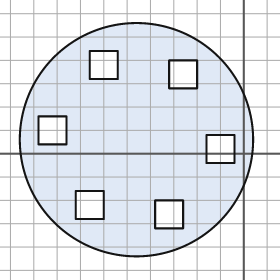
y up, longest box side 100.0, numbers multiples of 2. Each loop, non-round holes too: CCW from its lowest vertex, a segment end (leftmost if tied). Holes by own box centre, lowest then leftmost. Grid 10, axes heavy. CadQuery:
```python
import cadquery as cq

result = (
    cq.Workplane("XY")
    .moveTo(-46.0, 6.0)
    .circle(50.0)
    .moveTo(-38.0, -32.0)
    .lineTo(-26.0, -32.0)
    .lineTo(-26.0, -20.0)
    .lineTo(-38.0, -20.0)
    .close()
    .moveTo(-72.0, -28.0)
    .lineTo(-60.0, -28.0)
    .lineTo(-60.0, -16.0)
    .lineTo(-72.0, -16.0)
    .close()
    .moveTo(-16.0, -4.0)
    .lineTo(-4.0, -4.0)
    .lineTo(-4.0, 8.0)
    .lineTo(-16.0, 8.0)
    .close()
    .moveTo(-88.0, 4.0)
    .lineTo(-76.0, 4.0)
    .lineTo(-76.0, 16.0)
    .lineTo(-88.0, 16.0)
    .close()
    .moveTo(-32.0, 28.0)
    .lineTo(-20.0, 28.0)
    .lineTo(-20.0, 40.0)
    .lineTo(-32.0, 40.0)
    .close()
    .moveTo(-66.0, 32.0)
    .lineTo(-54.0, 32.0)
    .lineTo(-54.0, 44.0)
    .lineTo(-66.0, 44.0)
    .close()
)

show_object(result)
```